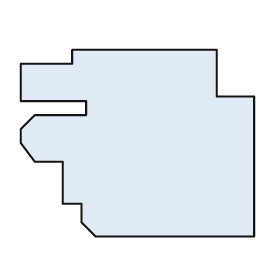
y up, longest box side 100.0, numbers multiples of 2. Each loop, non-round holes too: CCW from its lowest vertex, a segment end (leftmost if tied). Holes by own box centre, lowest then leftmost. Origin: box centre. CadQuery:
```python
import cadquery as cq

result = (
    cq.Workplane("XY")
    .moveTo(-18.0, -40.0)
    .lineTo(50.0, -40.0)
    .lineTo(50.0, 20.0)
    .lineTo(34.0, 20.0)
    .lineTo(34.0, 40.0)
    .lineTo(-28.0, 40.0)
    .lineTo(-28.0, 34.0)
    .lineTo(-50.0, 34.0)
    .lineTo(-50.0, 18.0)
    .lineTo(-22.0, 18.0)
    .lineTo(-22.0, 12.0)
    .lineTo(-44.0, 12.0)
    .lineTo(-50.0, 6.0)
    .lineTo(-50.0, 0.0)
    .lineTo(-44.0, -8.0)
    .lineTo(-32.0, -8.0)
    .lineTo(-32.0, -26.0)
    .lineTo(-24.0, -26.0)
    .lineTo(-24.0, -34.0)
    .close()
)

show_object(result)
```